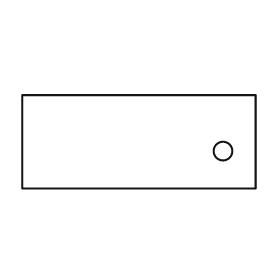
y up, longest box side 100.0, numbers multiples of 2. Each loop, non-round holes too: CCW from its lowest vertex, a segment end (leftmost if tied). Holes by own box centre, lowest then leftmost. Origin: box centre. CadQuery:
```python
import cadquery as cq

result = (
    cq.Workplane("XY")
    .moveTo(-50.0, -20.0)
    .lineTo(50.0, -20.0)
    .lineTo(50.0, 20.0)
    .lineTo(-50.0, 20.0)
    .close()
    .moveTo(36.0, -4.0)
    .circle(4.0)
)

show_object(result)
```